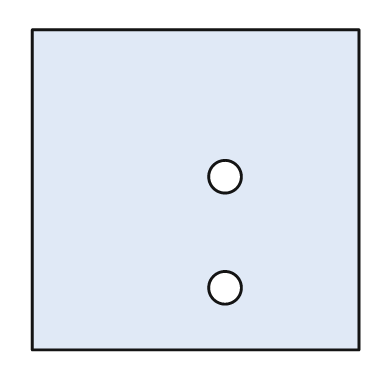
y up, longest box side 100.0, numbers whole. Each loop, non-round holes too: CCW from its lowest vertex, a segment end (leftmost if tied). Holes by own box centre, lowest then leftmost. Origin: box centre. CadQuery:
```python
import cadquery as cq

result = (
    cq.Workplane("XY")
    .moveTo(-50.0, -49.0)
    .lineTo(50.0, -49.0)
    .lineTo(50.0, 49.0)
    .lineTo(-50.0, 49.0)
    .close()
    .moveTo(9.0, -30.0)
    .circle(5.0)
    .moveTo(9.0, 4.0)
    .circle(5.0)
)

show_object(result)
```